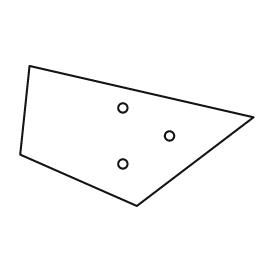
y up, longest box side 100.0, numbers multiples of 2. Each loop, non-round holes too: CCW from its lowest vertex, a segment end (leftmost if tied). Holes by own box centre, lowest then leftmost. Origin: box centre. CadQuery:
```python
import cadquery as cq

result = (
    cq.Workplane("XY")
    .moveTo(0.0, -30.0)
    .lineTo(50.0, 8.0)
    .lineTo(-46.0, 30.0)
    .lineTo(-50.0, -8.0)
    .close()
    .moveTo(-6.0, -12.0)
    .circle(2.0)
    .moveTo(14.0, 0.0)
    .circle(2.0)
    .moveTo(-6.0, 12.0)
    .circle(2.0)
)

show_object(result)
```